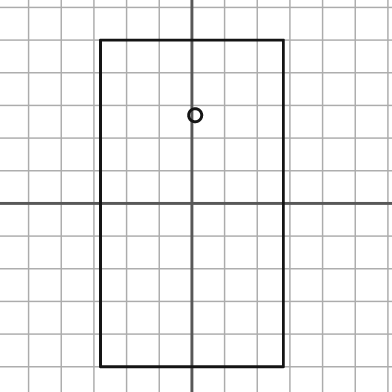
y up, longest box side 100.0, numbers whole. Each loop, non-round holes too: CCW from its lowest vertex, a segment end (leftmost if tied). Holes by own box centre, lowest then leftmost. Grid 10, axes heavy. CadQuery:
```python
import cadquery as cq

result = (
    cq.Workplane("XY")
    .moveTo(-28.0, -50.0)
    .lineTo(28.0, -50.0)
    .lineTo(28.0, 50.0)
    .lineTo(-28.0, 50.0)
    .close()
    .moveTo(1.0, 27.0)
    .circle(2.0)
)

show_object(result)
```